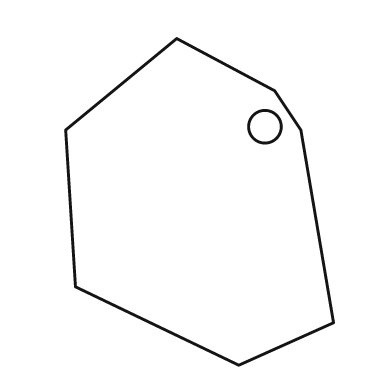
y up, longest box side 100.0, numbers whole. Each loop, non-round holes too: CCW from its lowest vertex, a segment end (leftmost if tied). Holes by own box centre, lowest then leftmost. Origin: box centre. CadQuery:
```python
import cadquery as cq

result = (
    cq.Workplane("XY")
    .moveTo(12.0, -50.0)
    .lineTo(41.0, -37.0)
    .lineTo(31.0, 22.0)
    .lineTo(23.0, 34.0)
    .lineTo(-7.0, 50.0)
    .lineTo(-41.0, 22.0)
    .lineTo(-38.0, -26.0)
    .close()
    .moveTo(20.0, 23.0)
    .circle(5.0)
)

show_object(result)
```